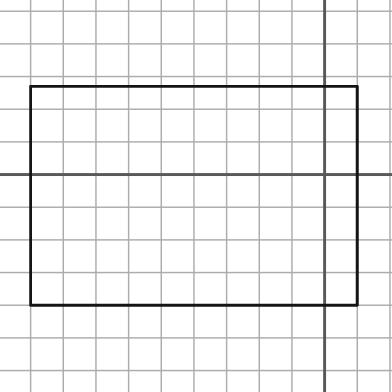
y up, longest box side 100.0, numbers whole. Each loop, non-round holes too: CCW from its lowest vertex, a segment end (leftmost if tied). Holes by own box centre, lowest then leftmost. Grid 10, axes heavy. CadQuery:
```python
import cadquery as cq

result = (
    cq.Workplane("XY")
    .moveTo(-90.0, -40.0)
    .lineTo(10.0, -40.0)
    .lineTo(10.0, 27.0)
    .lineTo(-90.0, 27.0)
    .close()
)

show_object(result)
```